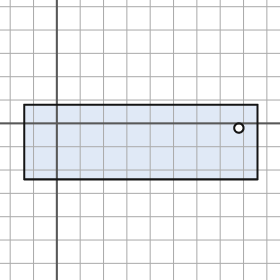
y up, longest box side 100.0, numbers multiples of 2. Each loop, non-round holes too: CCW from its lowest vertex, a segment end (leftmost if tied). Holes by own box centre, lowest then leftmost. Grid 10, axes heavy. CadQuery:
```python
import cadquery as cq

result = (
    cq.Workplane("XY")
    .moveTo(-14.0, -24.0)
    .lineTo(86.0, -24.0)
    .lineTo(86.0, 8.0)
    .lineTo(-14.0, 8.0)
    .close()
    .moveTo(78.0, -2.0)
    .circle(2.0)
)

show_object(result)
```